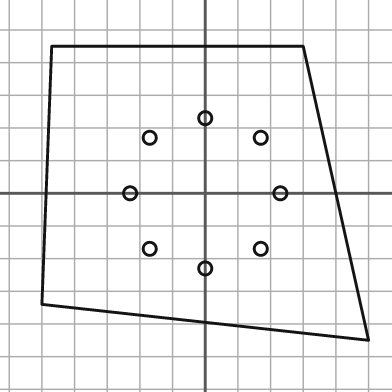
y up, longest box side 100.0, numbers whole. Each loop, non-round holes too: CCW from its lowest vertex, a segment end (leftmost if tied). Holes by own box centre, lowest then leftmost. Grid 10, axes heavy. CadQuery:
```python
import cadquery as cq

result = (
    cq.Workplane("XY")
    .moveTo(50.0, -45.0)
    .lineTo(30.0, 45.0)
    .lineTo(-47.0, 45.0)
    .lineTo(-50.0, -34.0)
    .close()
    .moveTo(0.0, -23.0)
    .circle(2.0)
    .moveTo(-17.0, -17.0)
    .circle(2.0)
    .moveTo(17.0, -17.0)
    .circle(2.0)
    .moveTo(-23.0, 0.0)
    .circle(2.0)
    .moveTo(23.0, 0.0)
    .circle(2.0)
    .moveTo(-17.0, 17.0)
    .circle(2.0)
    .moveTo(17.0, 17.0)
    .circle(2.0)
    .moveTo(0.0, 23.0)
    .circle(2.0)
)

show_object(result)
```